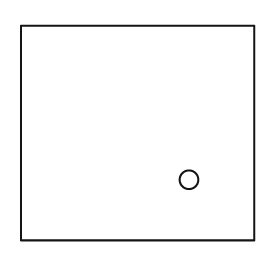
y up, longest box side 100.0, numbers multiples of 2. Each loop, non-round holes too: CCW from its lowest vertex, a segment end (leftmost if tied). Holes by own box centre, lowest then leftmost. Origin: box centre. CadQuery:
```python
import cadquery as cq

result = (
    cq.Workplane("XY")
    .moveTo(-50.0, -46.0)
    .lineTo(50.0, -46.0)
    .lineTo(50.0, 46.0)
    .lineTo(-50.0, 46.0)
    .close()
    .moveTo(22.0, -20.0)
    .circle(4.0)
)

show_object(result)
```